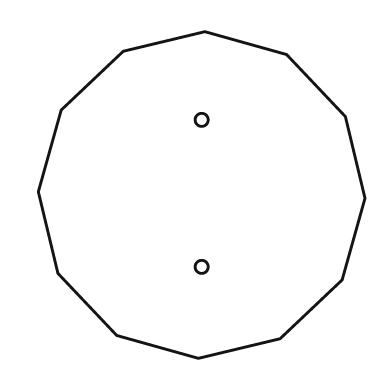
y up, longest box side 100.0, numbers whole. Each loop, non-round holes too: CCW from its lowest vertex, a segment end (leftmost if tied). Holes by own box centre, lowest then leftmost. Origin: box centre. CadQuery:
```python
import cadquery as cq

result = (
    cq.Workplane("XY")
    .moveTo(-1.0, -50.0)
    .lineTo(24.0, -44.0)
    .lineTo(43.0, -26.0)
    .lineTo(50.0, -1.0)
    .lineTo(44.0, 24.0)
    .lineTo(26.0, 43.0)
    .lineTo(1.0, 50.0)
    .lineTo(-24.0, 44.0)
    .lineTo(-43.0, 26.0)
    .lineTo(-50.0, 1.0)
    .lineTo(-44.0, -24.0)
    .lineTo(-26.0, -43.0)
    .close()
    .moveTo(0.0, -22.0)
    .circle(2.0)
    .moveTo(0.0, 23.0)
    .circle(2.0)
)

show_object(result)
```